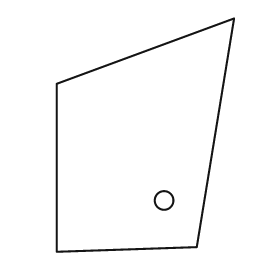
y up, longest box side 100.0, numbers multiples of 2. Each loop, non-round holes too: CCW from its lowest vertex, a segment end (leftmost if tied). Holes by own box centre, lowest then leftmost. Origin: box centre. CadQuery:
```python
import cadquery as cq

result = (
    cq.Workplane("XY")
    .moveTo(-38.0, -50.0)
    .lineTo(22.0, -48.0)
    .lineTo(38.0, 50.0)
    .lineTo(-38.0, 22.0)
    .close()
    .moveTo(8.0, -28.0)
    .circle(4.0)
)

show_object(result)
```